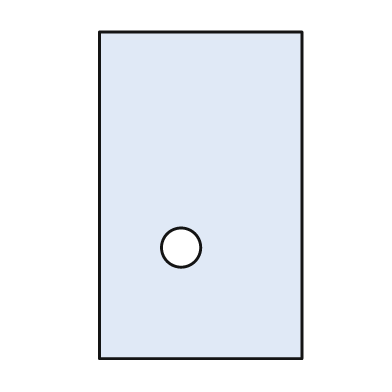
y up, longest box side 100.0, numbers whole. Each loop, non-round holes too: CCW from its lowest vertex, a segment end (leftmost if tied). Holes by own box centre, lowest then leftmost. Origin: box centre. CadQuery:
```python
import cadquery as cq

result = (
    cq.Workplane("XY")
    .moveTo(-31.0, -50.0)
    .lineTo(31.0, -50.0)
    .lineTo(31.0, 50.0)
    .lineTo(-31.0, 50.0)
    .close()
    .moveTo(-6.0, -16.0)
    .circle(6.0)
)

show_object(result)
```